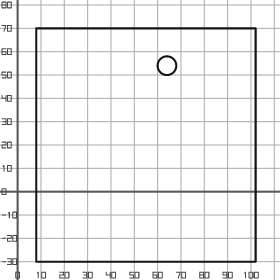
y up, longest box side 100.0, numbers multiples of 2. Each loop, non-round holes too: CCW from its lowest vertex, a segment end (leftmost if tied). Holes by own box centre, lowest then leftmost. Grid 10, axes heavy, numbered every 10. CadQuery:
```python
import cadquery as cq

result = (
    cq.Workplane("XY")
    .moveTo(8.0, -30.0)
    .lineTo(102.0, -30.0)
    .lineTo(102.0, 70.0)
    .lineTo(8.0, 70.0)
    .close()
    .moveTo(64.0, 54.0)
    .circle(4.0)
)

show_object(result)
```